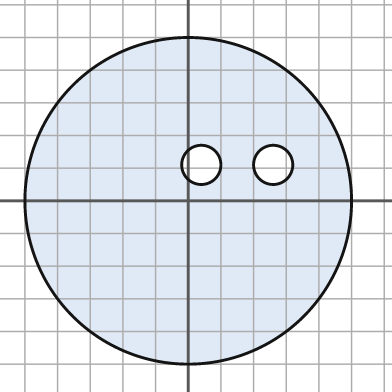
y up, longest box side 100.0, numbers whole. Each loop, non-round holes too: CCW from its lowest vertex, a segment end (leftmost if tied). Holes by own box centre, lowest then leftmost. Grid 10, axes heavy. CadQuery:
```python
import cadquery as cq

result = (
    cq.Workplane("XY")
    .moveTo(0.0, 0.0)
    .circle(50.0)
    .moveTo(4.0, 11.0)
    .circle(6.0)
    .moveTo(26.0, 11.0)
    .circle(6.0)
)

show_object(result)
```